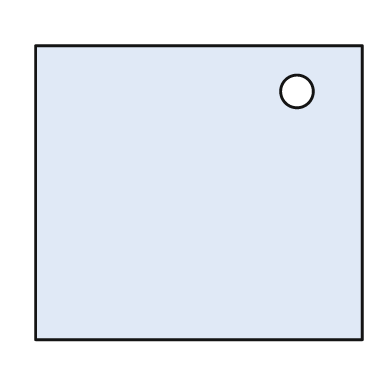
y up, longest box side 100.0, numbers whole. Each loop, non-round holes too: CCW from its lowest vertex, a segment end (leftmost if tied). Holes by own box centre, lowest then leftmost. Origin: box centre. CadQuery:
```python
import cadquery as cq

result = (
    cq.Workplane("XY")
    .moveTo(-50.0, -45.0)
    .lineTo(50.0, -45.0)
    .lineTo(50.0, 45.0)
    .lineTo(-50.0, 45.0)
    .close()
    .moveTo(30.0, 31.0)
    .circle(5.0)
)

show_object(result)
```